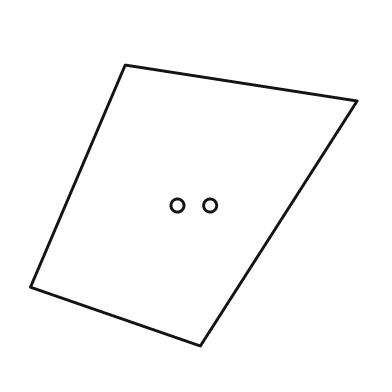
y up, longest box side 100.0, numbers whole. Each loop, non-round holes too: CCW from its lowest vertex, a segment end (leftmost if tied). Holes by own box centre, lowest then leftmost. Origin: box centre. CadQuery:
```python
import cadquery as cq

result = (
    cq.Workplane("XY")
    .moveTo(2.0, -43.0)
    .lineTo(50.0, 32.0)
    .lineTo(-21.0, 43.0)
    .lineTo(-50.0, -25.0)
    .close()
    .moveTo(-5.0, 0.0)
    .circle(2.0)
    .moveTo(5.0, 0.0)
    .circle(2.0)
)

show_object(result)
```